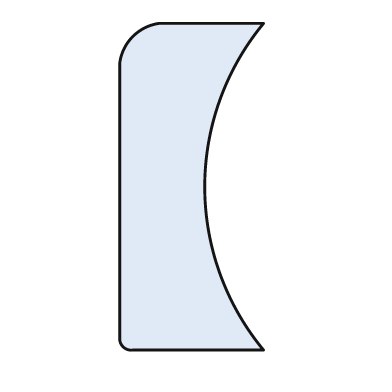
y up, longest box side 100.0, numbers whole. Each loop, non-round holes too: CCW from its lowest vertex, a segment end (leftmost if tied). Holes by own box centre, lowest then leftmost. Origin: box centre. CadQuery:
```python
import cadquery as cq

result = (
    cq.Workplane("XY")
    .moveTo(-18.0, -50.0)
    .lineTo(22.0, -50.0)
    .threePointArc((4.0, 0.0), (22.0, 50.0))
    .lineTo(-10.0, 50.0)
    .threePointArc((-18.0, 46.0), (-22.0, 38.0))
    .lineTo(-22.0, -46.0)
    .threePointArc((-21.0, -49.0), (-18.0, -50.0))
    .close()
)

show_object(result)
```